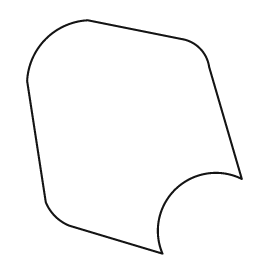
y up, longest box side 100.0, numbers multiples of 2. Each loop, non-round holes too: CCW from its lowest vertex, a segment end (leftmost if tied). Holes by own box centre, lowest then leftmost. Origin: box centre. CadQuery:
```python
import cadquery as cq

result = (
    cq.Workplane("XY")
    .moveTo(12.0, -50.0)
    .threePointArc((18.0, -22.0), (46.0, -18.0))
    .lineTo(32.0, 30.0)
    .threePointArc((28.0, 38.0), (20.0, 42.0))
    .lineTo(-20.0, 50.0)
    .threePointArc((-38.0, 42.0), (-46.0, 24.0))
    .lineTo(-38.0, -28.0)
    .threePointArc((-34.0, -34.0), (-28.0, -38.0))
    .close()
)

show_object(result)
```